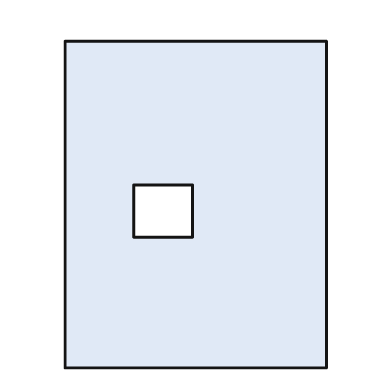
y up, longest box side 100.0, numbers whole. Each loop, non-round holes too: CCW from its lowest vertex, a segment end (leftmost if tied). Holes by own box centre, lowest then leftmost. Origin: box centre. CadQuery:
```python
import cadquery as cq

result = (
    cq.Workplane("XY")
    .moveTo(-40.0, -50.0)
    .lineTo(40.0, -50.0)
    .lineTo(40.0, 50.0)
    .lineTo(-40.0, 50.0)
    .close()
    .moveTo(-19.0, -10.0)
    .lineTo(-1.0, -10.0)
    .lineTo(-1.0, 6.0)
    .lineTo(-19.0, 6.0)
    .close()
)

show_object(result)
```